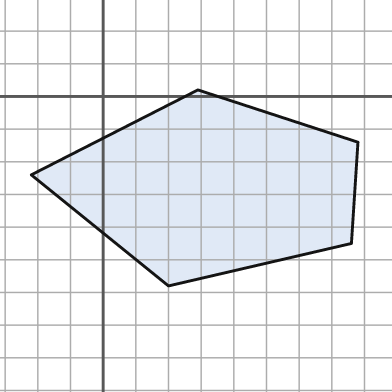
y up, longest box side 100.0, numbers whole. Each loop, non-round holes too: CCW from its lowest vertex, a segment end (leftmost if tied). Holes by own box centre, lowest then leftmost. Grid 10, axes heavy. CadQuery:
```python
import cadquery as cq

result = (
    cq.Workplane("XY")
    .moveTo(20.0, -58.0)
    .lineTo(76.0, -45.0)
    .lineTo(78.0, -14.0)
    .lineTo(29.0, 2.0)
    .lineTo(-22.0, -24.0)
    .close()
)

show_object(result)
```